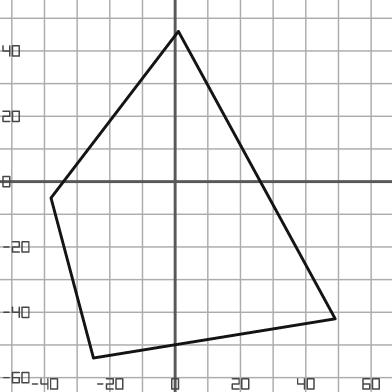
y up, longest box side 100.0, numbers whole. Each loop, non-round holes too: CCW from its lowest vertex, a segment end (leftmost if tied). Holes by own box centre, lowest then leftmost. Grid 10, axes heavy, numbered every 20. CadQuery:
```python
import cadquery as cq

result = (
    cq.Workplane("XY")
    .moveTo(-25.0, -54.0)
    .lineTo(49.0, -42.0)
    .lineTo(1.0, 46.0)
    .lineTo(-38.0, -5.0)
    .close()
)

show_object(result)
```